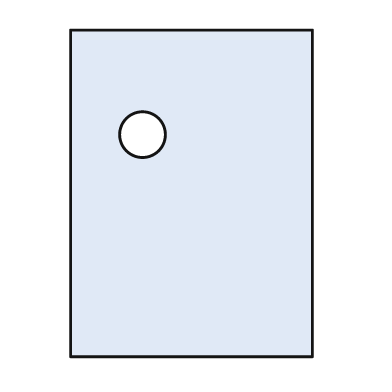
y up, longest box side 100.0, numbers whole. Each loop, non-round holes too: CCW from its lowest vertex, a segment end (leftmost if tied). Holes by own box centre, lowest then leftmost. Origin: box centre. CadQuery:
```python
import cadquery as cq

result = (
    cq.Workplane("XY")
    .moveTo(-37.0, -50.0)
    .lineTo(37.0, -50.0)
    .lineTo(37.0, 50.0)
    .lineTo(-37.0, 50.0)
    .close()
    .moveTo(-15.0, 18.0)
    .circle(7.0)
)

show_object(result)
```